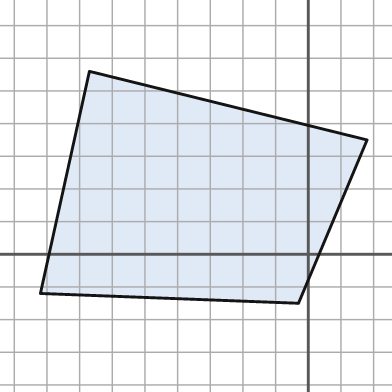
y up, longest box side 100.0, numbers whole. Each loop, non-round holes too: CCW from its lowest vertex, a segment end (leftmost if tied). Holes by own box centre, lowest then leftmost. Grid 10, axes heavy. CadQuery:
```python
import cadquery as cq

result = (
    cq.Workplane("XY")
    .moveTo(-3.0, -15.0)
    .lineTo(18.0, 35.0)
    .lineTo(-67.0, 56.0)
    .lineTo(-82.0, -12.0)
    .close()
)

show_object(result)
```